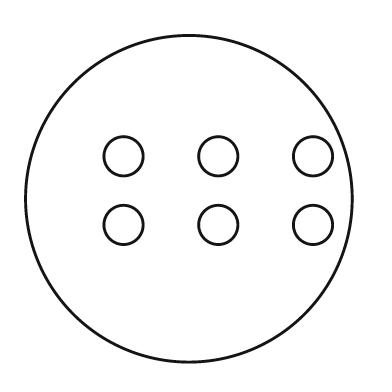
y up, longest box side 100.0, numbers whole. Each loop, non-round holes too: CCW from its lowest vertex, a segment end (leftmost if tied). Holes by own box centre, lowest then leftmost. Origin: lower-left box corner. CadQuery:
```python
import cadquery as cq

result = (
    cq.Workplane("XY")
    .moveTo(50.0, 50.0)
    .circle(50.0)
    .moveTo(30.0, 42.0)
    .circle(6.0)
    .moveTo(59.0, 42.0)
    .circle(6.0)
    .moveTo(88.0, 42.0)
    .circle(6.0)
    .moveTo(30.0, 63.0)
    .circle(6.0)
    .moveTo(59.0, 63.0)
    .circle(6.0)
    .moveTo(88.0, 63.0)
    .circle(6.0)
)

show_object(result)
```